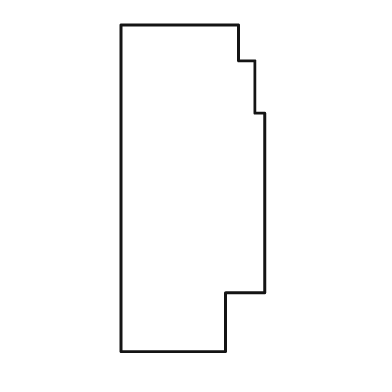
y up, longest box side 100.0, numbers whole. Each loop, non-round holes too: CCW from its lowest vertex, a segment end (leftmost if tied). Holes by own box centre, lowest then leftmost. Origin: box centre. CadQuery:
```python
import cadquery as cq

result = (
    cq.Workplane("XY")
    .moveTo(-22.0, -50.0)
    .lineTo(10.0, -50.0)
    .lineTo(10.0, -32.0)
    .lineTo(22.0, -32.0)
    .lineTo(22.0, 23.0)
    .lineTo(19.0, 23.0)
    .lineTo(19.0, 39.0)
    .lineTo(14.0, 39.0)
    .lineTo(14.0, 50.0)
    .lineTo(-22.0, 50.0)
    .close()
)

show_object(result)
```